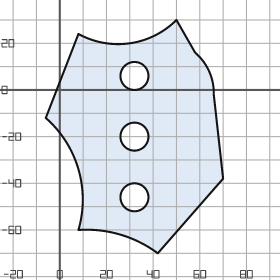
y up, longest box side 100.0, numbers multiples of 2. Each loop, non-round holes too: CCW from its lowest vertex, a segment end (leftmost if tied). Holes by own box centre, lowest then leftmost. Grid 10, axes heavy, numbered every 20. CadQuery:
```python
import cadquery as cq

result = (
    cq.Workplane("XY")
    .moveTo(42.0, -70.0)
    .lineTo(70.0, -38.0)
    .lineTo(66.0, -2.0)
    .threePointArc((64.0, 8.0), (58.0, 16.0))
    .lineTo(50.0, 30.0)
    .threePointArc((30.0, 20.0), (8.0, 24.0))
    .lineTo(-6.0, -12.0)
    .threePointArc((8.0, -34.0), (8.0, -60.0))
    .threePointArc((26.0, -62.0), (42.0, -70.0))
    .close()
    .moveTo(32.0, -46.0)
    .circle(6.0)
    .moveTo(32.0, -20.0)
    .circle(6.0)
    .moveTo(32.0, 6.0)
    .circle(6.0)
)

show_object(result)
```